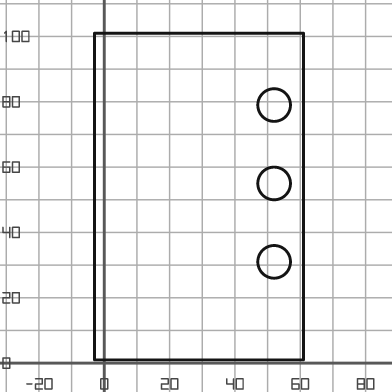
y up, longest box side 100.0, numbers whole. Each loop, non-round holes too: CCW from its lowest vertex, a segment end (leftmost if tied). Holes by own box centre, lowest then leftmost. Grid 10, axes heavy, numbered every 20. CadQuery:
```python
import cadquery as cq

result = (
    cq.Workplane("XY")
    .moveTo(-3.0, 1.0)
    .lineTo(61.0, 1.0)
    .lineTo(61.0, 101.0)
    .lineTo(-3.0, 101.0)
    .close()
    .moveTo(52.0, 31.0)
    .circle(5.0)
    .moveTo(52.0, 55.0)
    .circle(5.0)
    .moveTo(52.0, 79.0)
    .circle(5.0)
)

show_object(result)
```